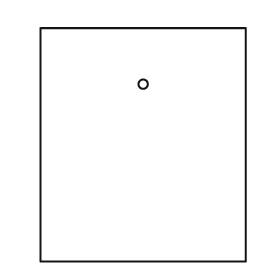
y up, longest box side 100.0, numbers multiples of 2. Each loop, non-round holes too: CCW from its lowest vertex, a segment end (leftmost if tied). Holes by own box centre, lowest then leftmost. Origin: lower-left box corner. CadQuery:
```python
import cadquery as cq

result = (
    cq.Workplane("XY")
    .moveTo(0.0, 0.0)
    .lineTo(88.0, 0.0)
    .lineTo(88.0, 100.0)
    .lineTo(0.0, 100.0)
    .close()
    .moveTo(44.0, 76.0)
    .circle(2.0)
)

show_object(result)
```